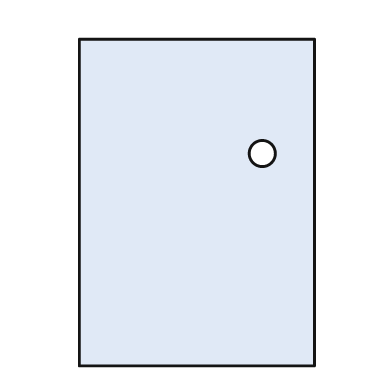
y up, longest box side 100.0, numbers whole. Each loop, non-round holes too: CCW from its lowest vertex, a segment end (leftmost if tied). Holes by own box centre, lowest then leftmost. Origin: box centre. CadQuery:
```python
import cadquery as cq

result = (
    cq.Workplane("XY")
    .moveTo(-36.0, -50.0)
    .lineTo(36.0, -50.0)
    .lineTo(36.0, 50.0)
    .lineTo(-36.0, 50.0)
    .close()
    .moveTo(20.0, 15.0)
    .circle(4.0)
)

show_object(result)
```